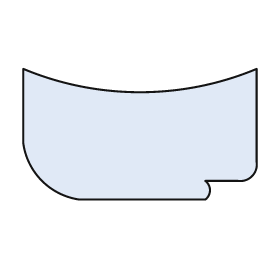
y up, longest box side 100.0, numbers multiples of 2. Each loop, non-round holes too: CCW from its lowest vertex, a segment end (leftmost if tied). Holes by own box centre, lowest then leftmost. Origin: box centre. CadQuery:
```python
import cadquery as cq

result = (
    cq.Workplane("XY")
    .moveTo(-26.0, -28.0)
    .lineTo(28.0, -28.0)
    .threePointArc((30.0, -24.0), (28.0, -20.0))
    .lineTo(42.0, -20.0)
    .threePointArc((48.0, -18.0), (50.0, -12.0))
    .lineTo(50.0, 28.0)
    .threePointArc((0.0, 18.0), (-50.0, 28.0))
    .lineTo(-50.0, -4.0)
    .threePointArc((-42.0, -20.0), (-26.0, -28.0))
    .close()
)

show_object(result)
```